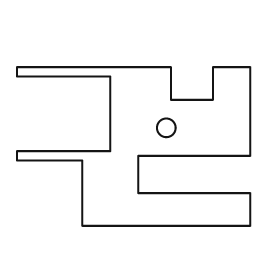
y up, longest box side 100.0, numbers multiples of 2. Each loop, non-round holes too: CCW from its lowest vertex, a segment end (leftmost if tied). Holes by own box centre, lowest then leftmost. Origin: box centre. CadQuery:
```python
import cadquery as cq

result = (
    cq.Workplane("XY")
    .moveTo(-22.0, -34.0)
    .lineTo(50.0, -34.0)
    .lineTo(50.0, -20.0)
    .lineTo(2.0, -20.0)
    .lineTo(2.0, -4.0)
    .lineTo(50.0, -4.0)
    .lineTo(50.0, 34.0)
    .lineTo(34.0, 34.0)
    .lineTo(34.0, 20.0)
    .lineTo(16.0, 20.0)
    .lineTo(16.0, 34.0)
    .lineTo(-50.0, 34.0)
    .lineTo(-50.0, 30.0)
    .lineTo(-10.0, 30.0)
    .lineTo(-10.0, -2.0)
    .lineTo(-50.0, -2.0)
    .lineTo(-50.0, -6.0)
    .lineTo(-22.0, -6.0)
    .close()
    .moveTo(14.0, 8.0)
    .circle(4.0)
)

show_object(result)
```